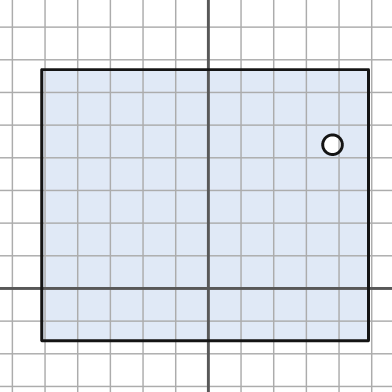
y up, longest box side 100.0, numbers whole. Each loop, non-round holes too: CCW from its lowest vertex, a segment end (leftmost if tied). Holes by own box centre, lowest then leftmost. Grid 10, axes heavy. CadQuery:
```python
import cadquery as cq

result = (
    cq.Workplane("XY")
    .moveTo(-51.0, -16.0)
    .lineTo(49.0, -16.0)
    .lineTo(49.0, 67.0)
    .lineTo(-51.0, 67.0)
    .close()
    .moveTo(38.0, 44.0)
    .circle(3.0)
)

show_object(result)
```